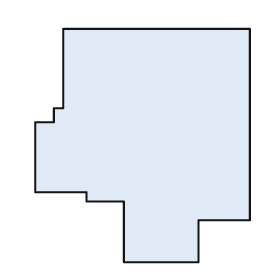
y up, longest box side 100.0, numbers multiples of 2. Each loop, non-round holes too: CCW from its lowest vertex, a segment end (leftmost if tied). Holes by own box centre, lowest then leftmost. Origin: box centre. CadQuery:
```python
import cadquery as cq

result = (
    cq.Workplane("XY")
    .moveTo(-8.0, -50.0)
    .lineTo(24.0, -50.0)
    .lineTo(24.0, -32.0)
    .lineTo(46.0, -32.0)
    .lineTo(46.0, 50.0)
    .lineTo(-34.0, 50.0)
    .lineTo(-34.0, 16.0)
    .lineTo(-38.0, 16.0)
    .lineTo(-38.0, 10.0)
    .lineTo(-46.0, 10.0)
    .lineTo(-46.0, -20.0)
    .lineTo(-24.0, -20.0)
    .lineTo(-24.0, -24.0)
    .lineTo(-8.0, -24.0)
    .close()
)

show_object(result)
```